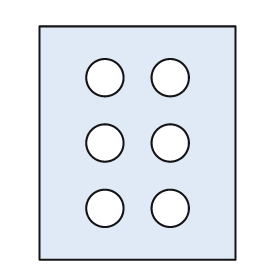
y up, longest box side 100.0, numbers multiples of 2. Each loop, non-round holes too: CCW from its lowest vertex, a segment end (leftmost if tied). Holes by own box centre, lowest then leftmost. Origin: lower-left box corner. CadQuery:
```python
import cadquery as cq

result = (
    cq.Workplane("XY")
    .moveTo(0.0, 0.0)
    .lineTo(84.0, 0.0)
    .lineTo(84.0, 100.0)
    .lineTo(0.0, 100.0)
    .close()
    .moveTo(28.0, 22.0)
    .circle(8.0)
    .moveTo(56.0, 22.0)
    .circle(8.0)
    .moveTo(28.0, 50.0)
    .circle(8.0)
    .moveTo(56.0, 50.0)
    .circle(8.0)
    .moveTo(28.0, 78.0)
    .circle(8.0)
    .moveTo(56.0, 78.0)
    .circle(8.0)
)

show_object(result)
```